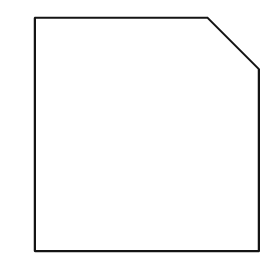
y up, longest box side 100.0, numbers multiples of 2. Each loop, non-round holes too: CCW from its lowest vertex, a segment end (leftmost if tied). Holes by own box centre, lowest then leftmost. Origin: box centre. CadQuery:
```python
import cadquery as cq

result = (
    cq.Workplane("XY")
    .moveTo(-48.0, -50.0)
    .lineTo(48.0, -50.0)
    .lineTo(48.0, 28.0)
    .lineTo(26.0, 50.0)
    .lineTo(-48.0, 50.0)
    .close()
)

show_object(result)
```